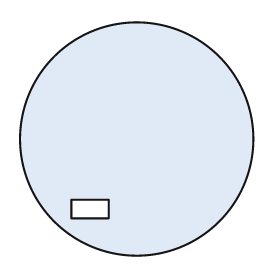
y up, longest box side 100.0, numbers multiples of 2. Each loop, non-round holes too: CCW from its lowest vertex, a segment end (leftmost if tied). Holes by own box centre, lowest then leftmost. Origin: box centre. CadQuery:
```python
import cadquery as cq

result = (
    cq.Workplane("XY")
    .moveTo(0.0, 0.0)
    .circle(50.0)
    .moveTo(-28.0, -34.0)
    .lineTo(-12.0, -34.0)
    .lineTo(-12.0, -26.0)
    .lineTo(-28.0, -26.0)
    .close()
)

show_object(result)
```